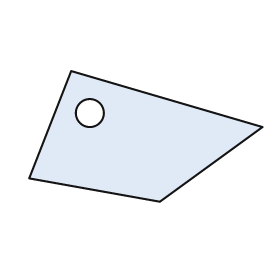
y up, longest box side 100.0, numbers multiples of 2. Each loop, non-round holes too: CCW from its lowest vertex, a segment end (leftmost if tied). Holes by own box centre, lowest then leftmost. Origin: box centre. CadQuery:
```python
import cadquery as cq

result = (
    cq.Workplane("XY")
    .moveTo(6.0, -28.0)
    .lineTo(50.0, 4.0)
    .lineTo(-32.0, 28.0)
    .lineTo(-50.0, -18.0)
    .close()
    .moveTo(-24.0, 10.0)
    .circle(6.0)
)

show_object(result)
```